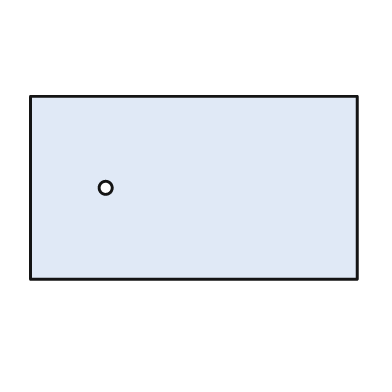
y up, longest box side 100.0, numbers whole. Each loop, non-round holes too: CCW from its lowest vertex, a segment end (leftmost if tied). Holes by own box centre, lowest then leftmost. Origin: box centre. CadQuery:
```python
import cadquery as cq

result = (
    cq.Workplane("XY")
    .moveTo(-50.0, -28.0)
    .lineTo(50.0, -28.0)
    .lineTo(50.0, 28.0)
    .lineTo(-50.0, 28.0)
    .close()
    .moveTo(-27.0, 0.0)
    .circle(2.0)
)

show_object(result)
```